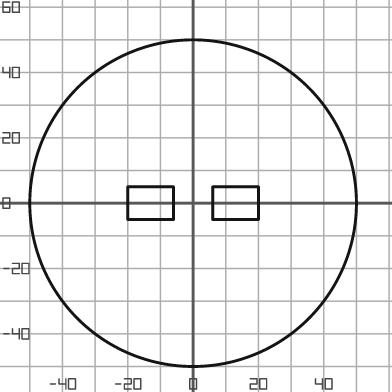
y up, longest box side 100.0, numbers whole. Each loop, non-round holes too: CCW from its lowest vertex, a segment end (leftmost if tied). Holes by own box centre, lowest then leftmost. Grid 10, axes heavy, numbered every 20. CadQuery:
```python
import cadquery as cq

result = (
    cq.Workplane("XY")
    .moveTo(0.0, 0.0)
    .circle(50.0)
    .moveTo(-20.0, -5.0)
    .lineTo(-6.0, -5.0)
    .lineTo(-6.0, 5.0)
    .lineTo(-20.0, 5.0)
    .close()
    .moveTo(6.0, -5.0)
    .lineTo(20.0, -5.0)
    .lineTo(20.0, 5.0)
    .lineTo(6.0, 5.0)
    .close()
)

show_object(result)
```